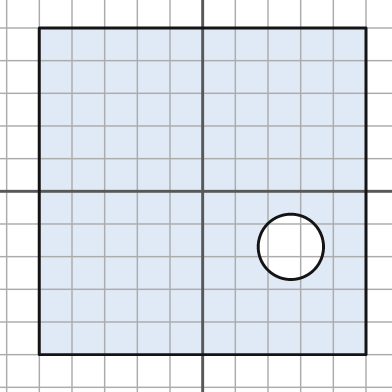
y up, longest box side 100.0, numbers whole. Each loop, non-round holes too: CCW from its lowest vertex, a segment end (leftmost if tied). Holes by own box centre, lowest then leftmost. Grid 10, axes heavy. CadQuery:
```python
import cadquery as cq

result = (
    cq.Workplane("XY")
    .moveTo(-50.0, -50.0)
    .lineTo(50.0, -50.0)
    .lineTo(50.0, 50.0)
    .lineTo(-50.0, 50.0)
    .close()
    .moveTo(27.0, -17.0)
    .circle(10.0)
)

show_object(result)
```